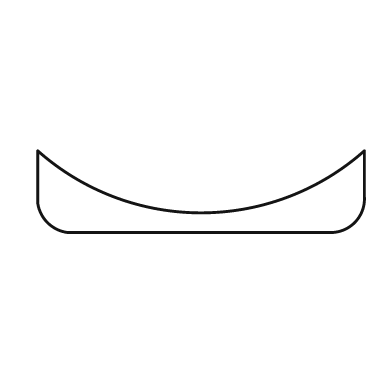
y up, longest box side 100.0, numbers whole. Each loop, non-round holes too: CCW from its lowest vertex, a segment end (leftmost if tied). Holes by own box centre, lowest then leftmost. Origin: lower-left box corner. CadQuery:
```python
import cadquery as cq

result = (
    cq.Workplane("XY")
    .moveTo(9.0, 0.0)
    .lineTo(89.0, 0.0)
    .threePointArc((97.0, 3.0), (100.0, 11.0))
    .lineTo(100.0, 25.0)
    .threePointArc((50.0, 6.0), (0.0, 25.0))
    .lineTo(0.0, 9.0)
    .threePointArc((3.0, 3.0), (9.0, 0.0))
    .close()
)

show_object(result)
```